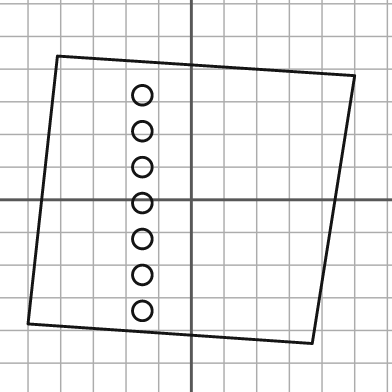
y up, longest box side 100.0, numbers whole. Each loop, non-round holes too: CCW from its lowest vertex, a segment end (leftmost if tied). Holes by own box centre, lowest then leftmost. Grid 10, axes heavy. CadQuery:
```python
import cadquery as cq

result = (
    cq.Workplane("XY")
    .moveTo(37.0, -44.0)
    .lineTo(50.0, 38.0)
    .lineTo(-41.0, 44.0)
    .lineTo(-50.0, -38.0)
    .close()
    .moveTo(-15.0, -34.0)
    .circle(3.0)
    .moveTo(-15.0, -23.0)
    .circle(3.0)
    .moveTo(-15.0, -12.0)
    .circle(3.0)
    .moveTo(-15.0, -1.0)
    .circle(3.0)
    .moveTo(-15.0, 10.0)
    .circle(3.0)
    .moveTo(-15.0, 21.0)
    .circle(3.0)
    .moveTo(-15.0, 32.0)
    .circle(3.0)
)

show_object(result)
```